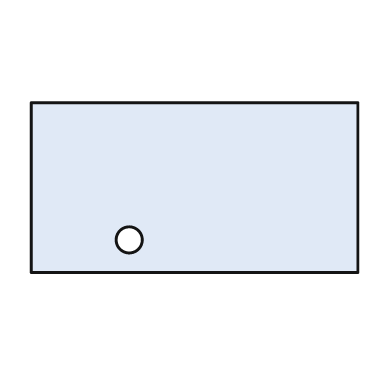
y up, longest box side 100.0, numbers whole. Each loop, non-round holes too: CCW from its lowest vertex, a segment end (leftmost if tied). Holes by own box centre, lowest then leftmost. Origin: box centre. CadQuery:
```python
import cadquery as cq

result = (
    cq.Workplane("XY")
    .moveTo(-50.0, -26.0)
    .lineTo(50.0, -26.0)
    .lineTo(50.0, 26.0)
    .lineTo(-50.0, 26.0)
    .close()
    .moveTo(-20.0, -16.0)
    .circle(4.0)
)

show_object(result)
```